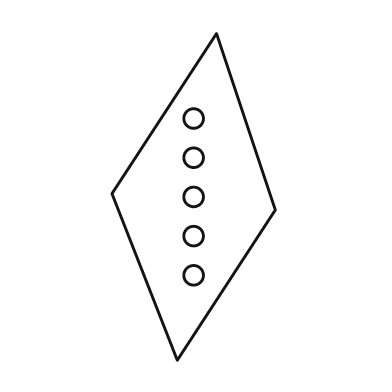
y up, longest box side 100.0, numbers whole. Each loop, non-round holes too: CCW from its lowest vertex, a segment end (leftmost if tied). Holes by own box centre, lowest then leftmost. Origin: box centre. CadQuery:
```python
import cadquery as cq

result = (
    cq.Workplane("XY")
    .moveTo(-5.0, -50.0)
    .lineTo(25.0, -4.0)
    .lineTo(7.0, 50.0)
    .lineTo(-25.0, 1.0)
    .close()
    .moveTo(0.0, -24.0)
    .circle(3.0)
    .moveTo(0.0, -12.0)
    .circle(3.0)
    .moveTo(0.0, 0.0)
    .circle(3.0)
    .moveTo(0.0, 12.0)
    .circle(3.0)
    .moveTo(0.0, 24.0)
    .circle(3.0)
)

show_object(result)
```